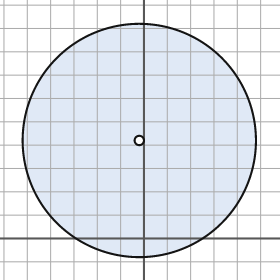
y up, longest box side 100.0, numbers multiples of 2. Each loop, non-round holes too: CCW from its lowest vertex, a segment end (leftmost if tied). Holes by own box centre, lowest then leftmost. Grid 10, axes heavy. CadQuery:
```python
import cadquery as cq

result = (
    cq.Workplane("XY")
    .moveTo(-2.0, 42.0)
    .circle(50.0)
    .moveTo(-2.0, 42.0)
    .circle(2.0)
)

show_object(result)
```